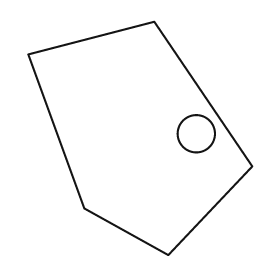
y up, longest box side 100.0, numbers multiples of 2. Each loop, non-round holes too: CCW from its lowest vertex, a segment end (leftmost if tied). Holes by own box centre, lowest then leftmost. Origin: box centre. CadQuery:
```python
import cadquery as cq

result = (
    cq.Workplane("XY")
    .moveTo(12.0, -50.0)
    .lineTo(48.0, -12.0)
    .lineTo(6.0, 50.0)
    .lineTo(-48.0, 36.0)
    .lineTo(-24.0, -30.0)
    .close()
    .moveTo(24.0, 2.0)
    .circle(8.0)
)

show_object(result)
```